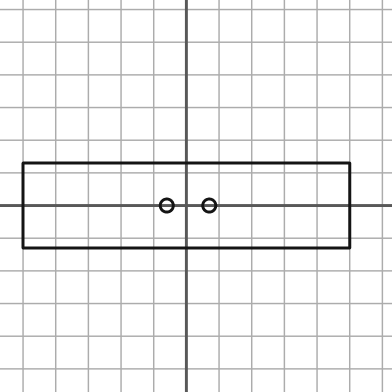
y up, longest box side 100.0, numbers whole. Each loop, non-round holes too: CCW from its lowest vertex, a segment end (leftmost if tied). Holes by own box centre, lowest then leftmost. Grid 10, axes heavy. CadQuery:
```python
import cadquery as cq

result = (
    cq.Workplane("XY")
    .moveTo(-50.0, -13.0)
    .lineTo(50.0, -13.0)
    .lineTo(50.0, 13.0)
    .lineTo(-50.0, 13.0)
    .close()
    .moveTo(-6.0, 0.0)
    .circle(2.0)
    .moveTo(7.0, 0.0)
    .circle(2.0)
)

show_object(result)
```